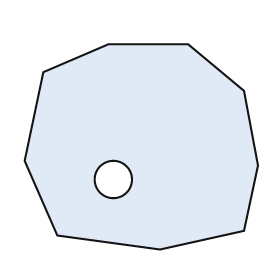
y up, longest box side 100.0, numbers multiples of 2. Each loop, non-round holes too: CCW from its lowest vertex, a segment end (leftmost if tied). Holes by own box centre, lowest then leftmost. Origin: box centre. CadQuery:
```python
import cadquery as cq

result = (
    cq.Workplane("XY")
    .moveTo(8.0, -44.0)
    .lineTo(44.0, -36.0)
    .lineTo(50.0, -8.0)
    .lineTo(44.0, 24.0)
    .lineTo(20.0, 44.0)
    .lineTo(-14.0, 44.0)
    .lineTo(-42.0, 32.0)
    .lineTo(-50.0, -6.0)
    .lineTo(-36.0, -38.0)
    .close()
    .moveTo(-12.0, -14.0)
    .circle(8.0)
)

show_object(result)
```